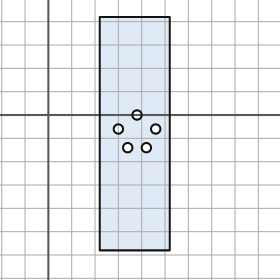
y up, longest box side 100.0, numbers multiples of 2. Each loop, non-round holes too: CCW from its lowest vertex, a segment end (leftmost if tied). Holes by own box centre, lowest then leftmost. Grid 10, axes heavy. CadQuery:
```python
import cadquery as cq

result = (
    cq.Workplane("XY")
    .moveTo(22.0, -58.0)
    .lineTo(52.0, -58.0)
    .lineTo(52.0, 42.0)
    .lineTo(22.0, 42.0)
    .close()
    .moveTo(34.0, -14.0)
    .circle(2.0)
    .moveTo(42.0, -14.0)
    .circle(2.0)
    .moveTo(30.0, -6.0)
    .circle(2.0)
    .moveTo(46.0, -6.0)
    .circle(2.0)
    .moveTo(38.0, 0.0)
    .circle(2.0)
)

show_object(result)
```